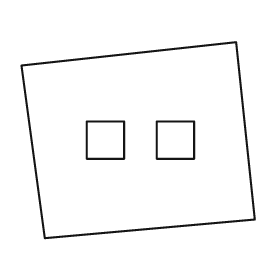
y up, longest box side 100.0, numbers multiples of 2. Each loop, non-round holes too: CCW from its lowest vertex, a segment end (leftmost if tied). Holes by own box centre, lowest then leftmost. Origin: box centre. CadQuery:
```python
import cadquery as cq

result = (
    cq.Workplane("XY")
    .moveTo(-40.0, -42.0)
    .lineTo(50.0, -34.0)
    .lineTo(42.0, 42.0)
    .lineTo(-50.0, 32.0)
    .close()
    .moveTo(-22.0, -8.0)
    .lineTo(-6.0, -8.0)
    .lineTo(-6.0, 8.0)
    .lineTo(-22.0, 8.0)
    .close()
    .moveTo(8.0, -8.0)
    .lineTo(24.0, -8.0)
    .lineTo(24.0, 8.0)
    .lineTo(8.0, 8.0)
    .close()
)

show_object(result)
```